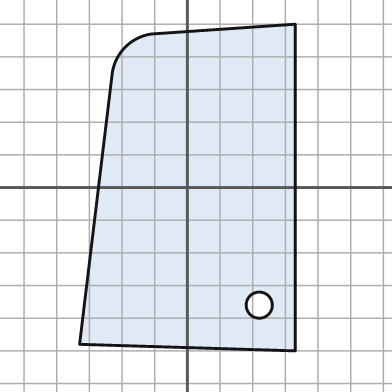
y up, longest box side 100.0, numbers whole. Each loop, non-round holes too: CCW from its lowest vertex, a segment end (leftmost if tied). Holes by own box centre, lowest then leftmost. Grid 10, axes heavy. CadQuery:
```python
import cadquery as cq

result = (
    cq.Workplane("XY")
    .moveTo(33.0, -50.0)
    .lineTo(33.0, 50.0)
    .lineTo(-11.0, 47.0)
    .threePointArc((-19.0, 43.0), (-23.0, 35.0))
    .lineTo(-33.0, -48.0)
    .close()
    .moveTo(22.0, -36.0)
    .circle(4.0)
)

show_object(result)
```